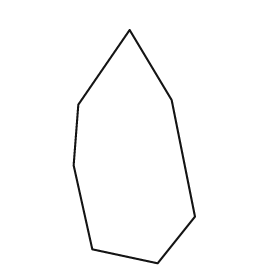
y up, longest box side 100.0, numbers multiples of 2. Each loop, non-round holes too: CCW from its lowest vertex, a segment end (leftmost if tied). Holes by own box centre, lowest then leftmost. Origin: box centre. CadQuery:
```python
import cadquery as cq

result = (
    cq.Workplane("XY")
    .moveTo(10.0, -50.0)
    .lineTo(26.0, -30.0)
    .lineTo(16.0, 20.0)
    .lineTo(-2.0, 50.0)
    .lineTo(-24.0, 18.0)
    .lineTo(-26.0, -8.0)
    .lineTo(-18.0, -44.0)
    .close()
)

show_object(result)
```